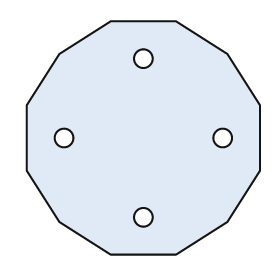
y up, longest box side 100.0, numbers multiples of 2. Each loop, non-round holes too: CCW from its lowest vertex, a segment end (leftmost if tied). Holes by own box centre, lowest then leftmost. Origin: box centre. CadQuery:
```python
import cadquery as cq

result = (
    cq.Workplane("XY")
    .moveTo(-14.0, -50.0)
    .lineTo(14.0, -50.0)
    .lineTo(36.0, -36.0)
    .lineTo(50.0, -14.0)
    .lineTo(50.0, 14.0)
    .lineTo(36.0, 36.0)
    .lineTo(14.0, 50.0)
    .lineTo(-14.0, 50.0)
    .lineTo(-36.0, 36.0)
    .lineTo(-50.0, 14.0)
    .lineTo(-50.0, -14.0)
    .lineTo(-36.0, -36.0)
    .close()
    .moveTo(0.0, -34.0)
    .circle(4.0)
    .moveTo(-34.0, 0.0)
    .circle(4.0)
    .moveTo(34.0, 0.0)
    .circle(4.0)
    .moveTo(0.0, 34.0)
    .circle(4.0)
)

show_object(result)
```